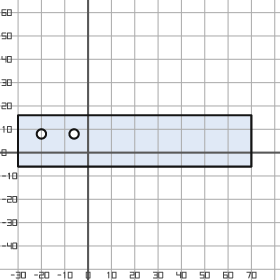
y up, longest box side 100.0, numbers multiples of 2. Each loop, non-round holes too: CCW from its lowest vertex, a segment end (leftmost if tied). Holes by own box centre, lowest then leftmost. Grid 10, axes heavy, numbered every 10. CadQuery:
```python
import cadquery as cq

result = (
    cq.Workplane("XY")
    .moveTo(-30.0, -6.0)
    .lineTo(70.0, -6.0)
    .lineTo(70.0, 16.0)
    .lineTo(-30.0, 16.0)
    .close()
    .moveTo(-20.0, 8.0)
    .circle(2.0)
    .moveTo(-6.0, 8.0)
    .circle(2.0)
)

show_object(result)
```